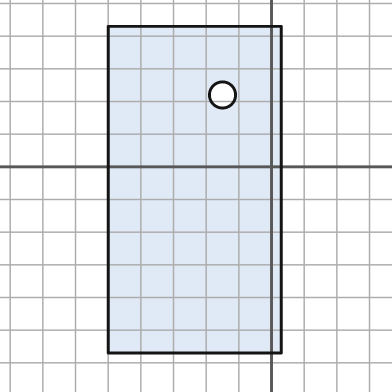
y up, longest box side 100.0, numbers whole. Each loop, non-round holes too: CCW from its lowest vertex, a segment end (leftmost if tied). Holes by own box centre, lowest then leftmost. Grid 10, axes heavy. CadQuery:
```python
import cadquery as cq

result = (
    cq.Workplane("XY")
    .moveTo(-50.0, -57.0)
    .lineTo(3.0, -57.0)
    .lineTo(3.0, 43.0)
    .lineTo(-50.0, 43.0)
    .close()
    .moveTo(-15.0, 22.0)
    .circle(4.0)
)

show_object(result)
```